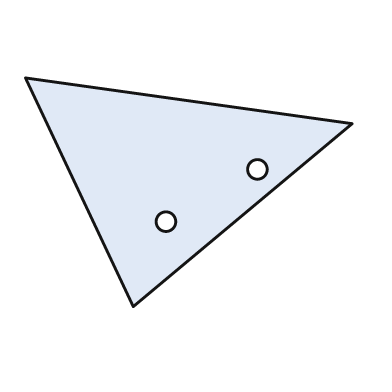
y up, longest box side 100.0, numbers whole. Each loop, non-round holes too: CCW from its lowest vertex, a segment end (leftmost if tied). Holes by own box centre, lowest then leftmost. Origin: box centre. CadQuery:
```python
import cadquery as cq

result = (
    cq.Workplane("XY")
    .moveTo(-17.0, -35.0)
    .lineTo(50.0, 21.0)
    .lineTo(-50.0, 35.0)
    .close()
    .moveTo(-7.0, -9.0)
    .circle(3.0)
    .moveTo(21.0, 7.0)
    .circle(3.0)
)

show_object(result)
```